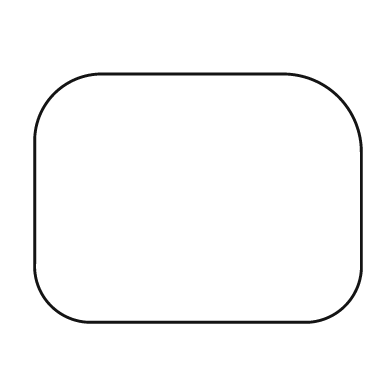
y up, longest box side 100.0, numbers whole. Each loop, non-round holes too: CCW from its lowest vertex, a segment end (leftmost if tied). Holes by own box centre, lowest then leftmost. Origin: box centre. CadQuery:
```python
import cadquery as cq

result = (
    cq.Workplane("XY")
    .moveTo(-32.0, -38.0)
    .lineTo(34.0, -38.0)
    .threePointArc((45.0, -33.0), (50.0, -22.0))
    .lineTo(50.0, 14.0)
    .threePointArc((43.0, 31.0), (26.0, 38.0))
    .lineTo(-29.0, 38.0)
    .threePointArc((-44.0, 32.0), (-50.0, 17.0))
    .lineTo(-50.0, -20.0)
    .threePointArc((-45.0, -33.0), (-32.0, -38.0))
    .close()
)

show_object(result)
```